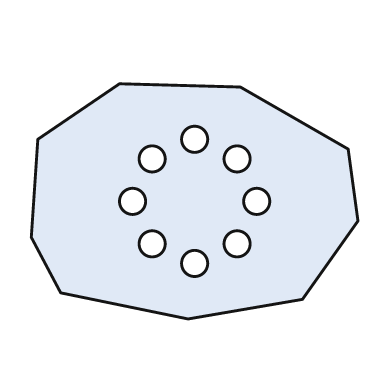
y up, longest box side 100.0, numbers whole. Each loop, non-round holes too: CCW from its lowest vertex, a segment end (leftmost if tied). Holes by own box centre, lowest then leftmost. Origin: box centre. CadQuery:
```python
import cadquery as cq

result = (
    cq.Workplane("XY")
    .moveTo(-2.0, -36.0)
    .lineTo(33.0, -30.0)
    .lineTo(50.0, -6.0)
    .lineTo(47.0, 16.0)
    .lineTo(14.0, 35.0)
    .lineTo(-23.0, 36.0)
    .lineTo(-48.0, 19.0)
    .lineTo(-50.0, -11.0)
    .lineTo(-41.0, -28.0)
    .close()
    .moveTo(0.0, -19.0)
    .circle(4.0)
    .moveTo(-13.0, -13.0)
    .circle(4.0)
    .moveTo(13.0, -13.0)
    .circle(4.0)
    .moveTo(-19.0, 0.0)
    .circle(4.0)
    .moveTo(19.0, 0.0)
    .circle(4.0)
    .moveTo(-13.0, 13.0)
    .circle(4.0)
    .moveTo(13.0, 13.0)
    .circle(4.0)
    .moveTo(0.0, 19.0)
    .circle(4.0)
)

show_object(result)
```